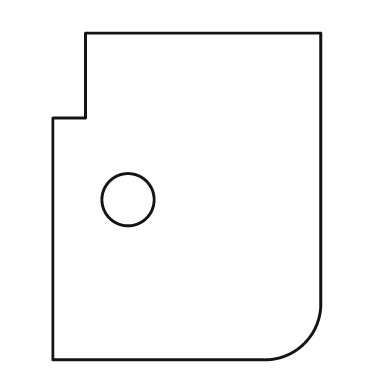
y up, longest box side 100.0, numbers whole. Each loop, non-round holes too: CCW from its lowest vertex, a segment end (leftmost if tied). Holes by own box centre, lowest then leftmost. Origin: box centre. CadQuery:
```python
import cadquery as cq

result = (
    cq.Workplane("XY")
    .moveTo(-41.0, -50.0)
    .lineTo(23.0, -50.0)
    .threePointArc((36.0, -45.0), (41.0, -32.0))
    .lineTo(41.0, 50.0)
    .lineTo(-31.0, 50.0)
    .lineTo(-31.0, 24.0)
    .lineTo(-41.0, 24.0)
    .close()
    .moveTo(-18.0, -1.0)
    .circle(8.0)
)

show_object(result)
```